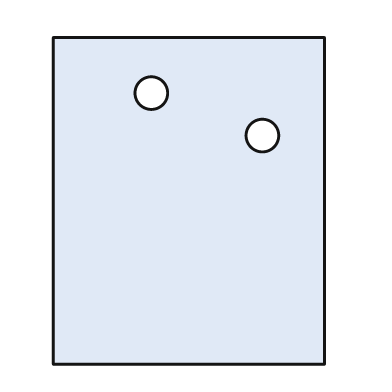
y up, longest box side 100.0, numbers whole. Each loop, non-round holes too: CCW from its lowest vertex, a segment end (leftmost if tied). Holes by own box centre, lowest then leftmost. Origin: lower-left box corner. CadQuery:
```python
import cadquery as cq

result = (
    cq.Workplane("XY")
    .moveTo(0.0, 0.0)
    .lineTo(83.0, 0.0)
    .lineTo(83.0, 100.0)
    .lineTo(0.0, 100.0)
    .close()
    .moveTo(64.0, 70.0)
    .circle(5.0)
    .moveTo(30.0, 83.0)
    .circle(5.0)
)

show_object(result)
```